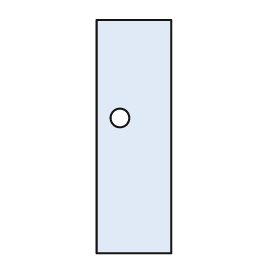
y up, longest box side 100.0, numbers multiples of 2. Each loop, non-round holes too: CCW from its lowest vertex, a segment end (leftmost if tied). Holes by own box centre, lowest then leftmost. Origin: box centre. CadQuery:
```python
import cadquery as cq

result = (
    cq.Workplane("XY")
    .moveTo(-16.0, -50.0)
    .lineTo(16.0, -50.0)
    .lineTo(16.0, 50.0)
    .lineTo(-16.0, 50.0)
    .close()
    .moveTo(-6.0, 8.0)
    .circle(4.0)
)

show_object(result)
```